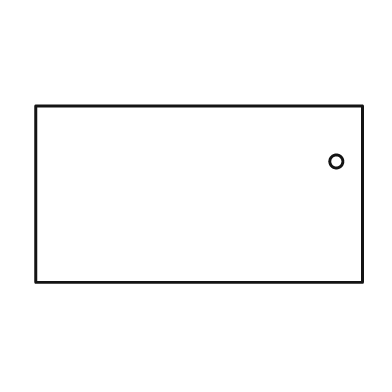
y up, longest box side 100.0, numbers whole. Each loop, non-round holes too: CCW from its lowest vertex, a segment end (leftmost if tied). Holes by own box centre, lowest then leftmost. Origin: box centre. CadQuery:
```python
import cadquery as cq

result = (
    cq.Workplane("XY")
    .moveTo(-50.0, -27.0)
    .lineTo(50.0, -27.0)
    .lineTo(50.0, 27.0)
    .lineTo(-50.0, 27.0)
    .close()
    .moveTo(42.0, 10.0)
    .circle(2.0)
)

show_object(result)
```